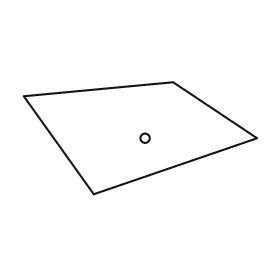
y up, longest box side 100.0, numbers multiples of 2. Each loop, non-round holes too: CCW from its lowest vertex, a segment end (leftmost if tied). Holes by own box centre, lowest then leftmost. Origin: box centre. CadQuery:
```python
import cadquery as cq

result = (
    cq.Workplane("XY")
    .moveTo(-20.0, -24.0)
    .lineTo(50.0, 0.0)
    .lineTo(14.0, 24.0)
    .lineTo(-50.0, 18.0)
    .close()
    .moveTo(2.0, 0.0)
    .circle(2.0)
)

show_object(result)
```